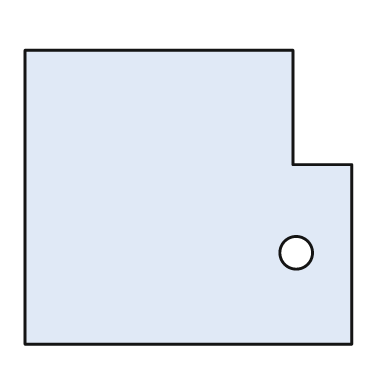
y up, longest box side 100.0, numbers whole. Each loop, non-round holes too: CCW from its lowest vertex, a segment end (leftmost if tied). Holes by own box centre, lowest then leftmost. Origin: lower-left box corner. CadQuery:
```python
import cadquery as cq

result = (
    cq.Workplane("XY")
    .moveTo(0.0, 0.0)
    .lineTo(100.0, 0.0)
    .lineTo(100.0, 55.0)
    .lineTo(82.0, 55.0)
    .lineTo(82.0, 90.0)
    .lineTo(0.0, 90.0)
    .close()
    .moveTo(83.0, 28.0)
    .circle(5.0)
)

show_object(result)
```